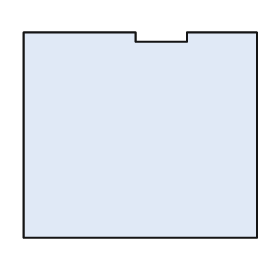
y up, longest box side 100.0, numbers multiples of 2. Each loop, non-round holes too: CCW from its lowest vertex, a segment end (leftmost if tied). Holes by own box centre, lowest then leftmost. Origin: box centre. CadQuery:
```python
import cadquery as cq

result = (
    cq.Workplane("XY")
    .moveTo(-50.0, -44.0)
    .lineTo(50.0, -44.0)
    .lineTo(50.0, 44.0)
    .lineTo(20.0, 44.0)
    .lineTo(20.0, 40.0)
    .lineTo(-2.0, 40.0)
    .lineTo(-2.0, 44.0)
    .lineTo(-50.0, 44.0)
    .close()
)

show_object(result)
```